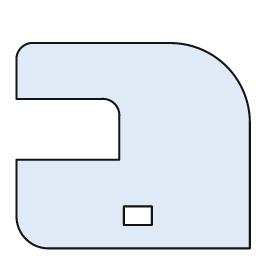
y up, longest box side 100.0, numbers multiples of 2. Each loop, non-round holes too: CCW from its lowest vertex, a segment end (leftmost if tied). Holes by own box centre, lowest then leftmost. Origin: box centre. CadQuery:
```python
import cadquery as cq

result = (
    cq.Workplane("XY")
    .moveTo(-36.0, -44.0)
    .lineTo(50.0, -44.0)
    .lineTo(50.0, 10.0)
    .threePointArc((40.0, 34.0), (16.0, 44.0))
    .lineTo(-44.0, 44.0)
    .threePointArc((-48.0, 42.0), (-50.0, 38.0))
    .lineTo(-50.0, 20.0)
    .lineTo(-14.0, 20.0)
    .threePointArc((-8.0, 18.0), (-6.0, 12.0))
    .lineTo(-6.0, -6.0)
    .lineTo(-50.0, -6.0)
    .lineTo(-50.0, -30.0)
    .threePointArc((-46.0, -40.0), (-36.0, -44.0))
    .close()
    .moveTo(-4.0, -34.0)
    .lineTo(8.0, -34.0)
    .lineTo(8.0, -26.0)
    .lineTo(-4.0, -26.0)
    .close()
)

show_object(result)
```